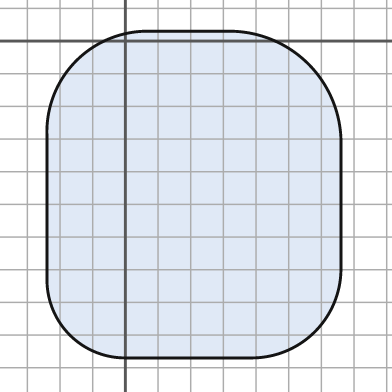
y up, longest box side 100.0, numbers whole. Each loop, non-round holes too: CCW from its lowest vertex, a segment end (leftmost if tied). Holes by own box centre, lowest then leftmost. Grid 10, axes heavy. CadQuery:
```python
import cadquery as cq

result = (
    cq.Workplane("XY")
    .moveTo(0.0, -97.0)
    .lineTo(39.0, -97.0)
    .threePointArc((58.0, -89.0), (66.0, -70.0))
    .lineTo(66.0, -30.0)
    .threePointArc((56.0, -7.0), (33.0, 3.0))
    .lineTo(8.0, 3.0)
    .threePointArc((-15.0, -6.0), (-24.0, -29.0))
    .lineTo(-24.0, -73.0)
    .threePointArc((-17.0, -90.0), (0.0, -97.0))
    .close()
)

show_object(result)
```